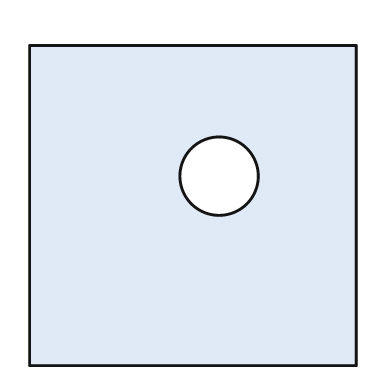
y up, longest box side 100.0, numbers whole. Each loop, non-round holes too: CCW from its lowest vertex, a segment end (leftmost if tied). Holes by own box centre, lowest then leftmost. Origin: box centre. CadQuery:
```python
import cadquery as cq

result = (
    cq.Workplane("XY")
    .moveTo(-50.0, -49.0)
    .lineTo(50.0, -49.0)
    .lineTo(50.0, 49.0)
    .lineTo(-50.0, 49.0)
    .close()
    .moveTo(8.0, 9.0)
    .circle(12.0)
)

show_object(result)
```